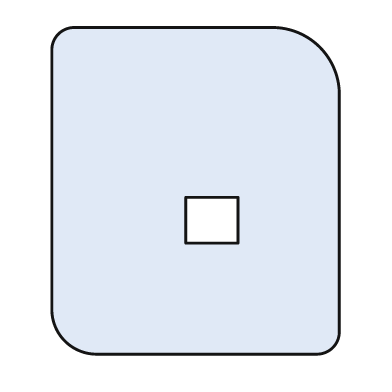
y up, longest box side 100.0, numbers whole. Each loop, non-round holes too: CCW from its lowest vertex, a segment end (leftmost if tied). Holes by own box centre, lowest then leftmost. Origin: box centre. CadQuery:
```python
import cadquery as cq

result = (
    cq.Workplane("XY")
    .moveTo(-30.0, -50.0)
    .lineTo(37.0, -50.0)
    .threePointArc((42.0, -48.0), (44.0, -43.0))
    .lineTo(44.0, 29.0)
    .threePointArc((38.0, 44.0), (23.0, 50.0))
    .lineTo(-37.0, 50.0)
    .threePointArc((-42.0, 48.0), (-44.0, 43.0))
    .lineTo(-44.0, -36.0)
    .threePointArc((-40.0, -46.0), (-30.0, -50.0))
    .close()
    .moveTo(-3.0, -16.0)
    .lineTo(13.0, -16.0)
    .lineTo(13.0, -2.0)
    .lineTo(-3.0, -2.0)
    .close()
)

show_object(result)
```